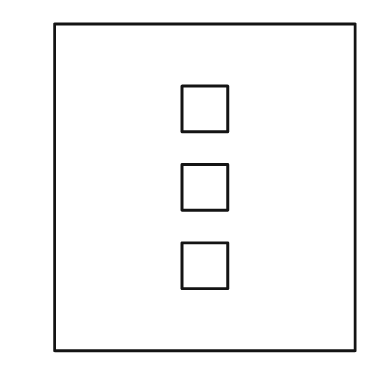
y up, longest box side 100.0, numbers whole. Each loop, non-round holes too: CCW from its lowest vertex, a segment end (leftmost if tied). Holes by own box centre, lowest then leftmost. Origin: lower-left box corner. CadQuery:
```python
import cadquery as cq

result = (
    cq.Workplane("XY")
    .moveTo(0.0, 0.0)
    .lineTo(92.0, 0.0)
    .lineTo(92.0, 100.0)
    .lineTo(0.0, 100.0)
    .close()
    .moveTo(39.0, 19.0)
    .lineTo(53.0, 19.0)
    .lineTo(53.0, 33.0)
    .lineTo(39.0, 33.0)
    .close()
    .moveTo(39.0, 43.0)
    .lineTo(53.0, 43.0)
    .lineTo(53.0, 57.0)
    .lineTo(39.0, 57.0)
    .close()
    .moveTo(39.0, 67.0)
    .lineTo(53.0, 67.0)
    .lineTo(53.0, 81.0)
    .lineTo(39.0, 81.0)
    .close()
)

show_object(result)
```